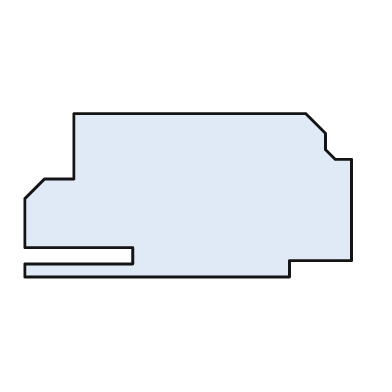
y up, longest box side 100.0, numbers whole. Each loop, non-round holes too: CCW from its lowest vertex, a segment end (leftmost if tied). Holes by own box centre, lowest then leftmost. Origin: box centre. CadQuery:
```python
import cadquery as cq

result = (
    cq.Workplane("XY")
    .moveTo(-50.0, -25.0)
    .lineTo(31.0, -25.0)
    .lineTo(31.0, -20.0)
    .lineTo(50.0, -20.0)
    .lineTo(50.0, 11.0)
    .lineTo(45.0, 11.0)
    .lineTo(42.0, 14.0)
    .lineTo(42.0, 19.0)
    .lineTo(36.0, 25.0)
    .lineTo(-35.0, 25.0)
    .lineTo(-35.0, 5.0)
    .lineTo(-44.0, 5.0)
    .lineTo(-50.0, -1.0)
    .lineTo(-50.0, -16.0)
    .lineTo(-17.0, -16.0)
    .lineTo(-17.0, -21.0)
    .lineTo(-50.0, -21.0)
    .close()
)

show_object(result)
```